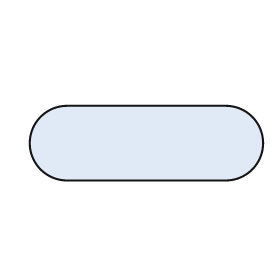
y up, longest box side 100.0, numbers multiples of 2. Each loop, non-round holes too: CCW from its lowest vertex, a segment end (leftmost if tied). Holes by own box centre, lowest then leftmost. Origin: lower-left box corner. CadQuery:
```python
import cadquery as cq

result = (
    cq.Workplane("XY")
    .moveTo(16.0, 0.0)
    .lineTo(84.0, 0.0)
    .threePointArc((100.0, 16.0), (84.0, 32.0))
    .lineTo(16.0, 32.0)
    .threePointArc((0.0, 16.0), (16.0, 0.0))
    .close()
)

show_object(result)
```